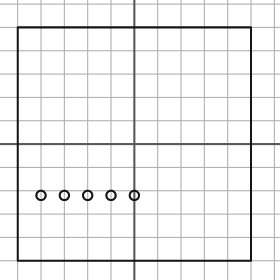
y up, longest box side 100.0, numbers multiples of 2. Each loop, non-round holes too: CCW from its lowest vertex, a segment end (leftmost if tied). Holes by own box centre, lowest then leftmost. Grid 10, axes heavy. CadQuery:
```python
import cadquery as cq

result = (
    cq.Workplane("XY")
    .moveTo(-50.0, -50.0)
    .lineTo(50.0, -50.0)
    .lineTo(50.0, 50.0)
    .lineTo(-50.0, 50.0)
    .close()
    .moveTo(-40.0, -22.0)
    .circle(2.0)
    .moveTo(-30.0, -22.0)
    .circle(2.0)
    .moveTo(-20.0, -22.0)
    .circle(2.0)
    .moveTo(-10.0, -22.0)
    .circle(2.0)
    .moveTo(0.0, -22.0)
    .circle(2.0)
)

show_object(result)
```